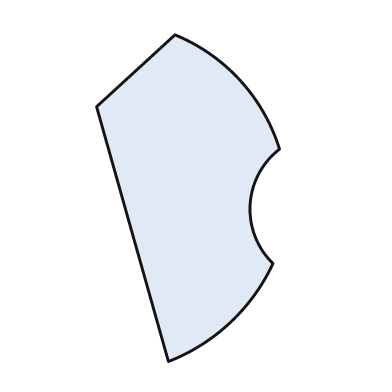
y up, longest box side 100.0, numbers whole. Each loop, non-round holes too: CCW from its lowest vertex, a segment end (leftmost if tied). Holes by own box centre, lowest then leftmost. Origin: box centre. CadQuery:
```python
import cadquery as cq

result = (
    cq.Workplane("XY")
    .moveTo(-6.0, -50.0)
    .threePointArc((13.0, -38.0), (26.0, -20.0))
    .threePointArc((19.0, -2.0), (28.0, 15.0))
    .threePointArc((16.0, 36.0), (-4.0, 50.0))
    .lineTo(-28.0, 28.0)
    .close()
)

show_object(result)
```